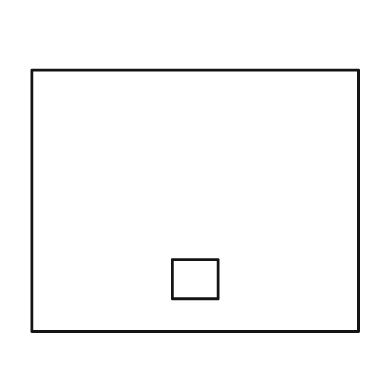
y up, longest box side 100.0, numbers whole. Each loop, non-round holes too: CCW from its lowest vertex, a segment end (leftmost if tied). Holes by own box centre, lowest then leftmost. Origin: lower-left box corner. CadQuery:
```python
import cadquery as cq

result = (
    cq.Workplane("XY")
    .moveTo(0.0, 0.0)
    .lineTo(100.0, 0.0)
    .lineTo(100.0, 80.0)
    .lineTo(0.0, 80.0)
    .close()
    .moveTo(43.0, 10.0)
    .lineTo(57.0, 10.0)
    .lineTo(57.0, 22.0)
    .lineTo(43.0, 22.0)
    .close()
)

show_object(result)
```